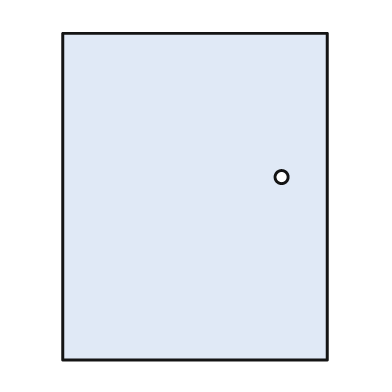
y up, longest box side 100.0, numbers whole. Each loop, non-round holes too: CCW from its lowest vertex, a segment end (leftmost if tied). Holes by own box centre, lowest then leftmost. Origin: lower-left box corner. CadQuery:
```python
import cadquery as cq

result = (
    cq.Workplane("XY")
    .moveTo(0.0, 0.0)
    .lineTo(81.0, 0.0)
    .lineTo(81.0, 100.0)
    .lineTo(0.0, 100.0)
    .close()
    .moveTo(67.0, 56.0)
    .circle(2.0)
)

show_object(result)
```